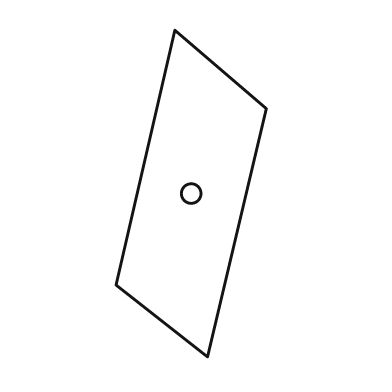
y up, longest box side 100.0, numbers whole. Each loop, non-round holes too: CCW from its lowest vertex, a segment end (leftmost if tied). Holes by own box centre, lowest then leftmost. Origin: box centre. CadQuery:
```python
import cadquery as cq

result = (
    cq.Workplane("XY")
    .moveTo(5.0, -50.0)
    .lineTo(23.0, 26.0)
    .lineTo(-5.0, 50.0)
    .lineTo(-23.0, -28.0)
    .close()
    .moveTo(0.0, 0.0)
    .circle(3.0)
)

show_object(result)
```